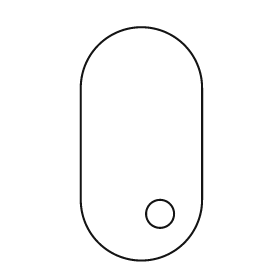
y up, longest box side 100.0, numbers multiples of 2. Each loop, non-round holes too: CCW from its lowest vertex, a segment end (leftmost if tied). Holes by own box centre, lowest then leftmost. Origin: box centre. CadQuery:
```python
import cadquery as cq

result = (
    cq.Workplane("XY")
    .moveTo(-26.0, -24.0)
    .threePointArc((0.0, -50.0), (26.0, -24.0))
    .lineTo(26.0, 24.0)
    .threePointArc((0.0, 50.0), (-26.0, 24.0))
    .close()
    .moveTo(8.0, -30.0)
    .circle(6.0)
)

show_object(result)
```